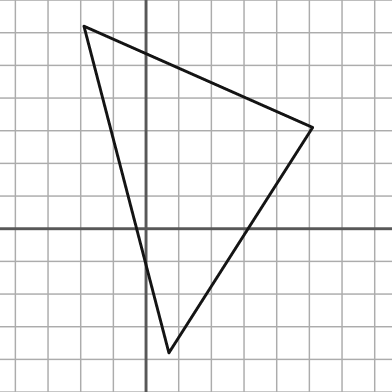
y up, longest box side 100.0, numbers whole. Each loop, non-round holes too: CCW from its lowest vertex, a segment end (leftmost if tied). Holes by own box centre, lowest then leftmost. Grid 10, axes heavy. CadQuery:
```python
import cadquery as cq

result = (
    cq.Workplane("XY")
    .moveTo(7.0, -38.0)
    .lineTo(51.0, 31.0)
    .lineTo(-19.0, 62.0)
    .close()
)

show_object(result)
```